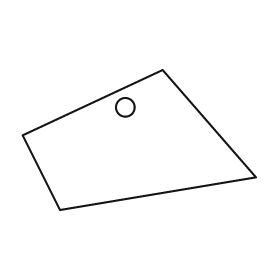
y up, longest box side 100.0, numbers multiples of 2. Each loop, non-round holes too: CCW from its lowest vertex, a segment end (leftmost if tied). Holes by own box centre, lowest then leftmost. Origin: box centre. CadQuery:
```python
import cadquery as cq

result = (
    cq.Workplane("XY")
    .moveTo(-34.0, -30.0)
    .lineTo(50.0, -16.0)
    .lineTo(10.0, 30.0)
    .lineTo(-50.0, 2.0)
    .close()
    .moveTo(-6.0, 14.0)
    .circle(4.0)
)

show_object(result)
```